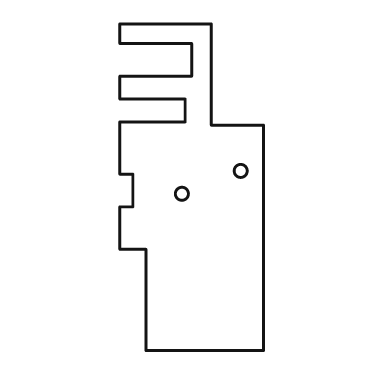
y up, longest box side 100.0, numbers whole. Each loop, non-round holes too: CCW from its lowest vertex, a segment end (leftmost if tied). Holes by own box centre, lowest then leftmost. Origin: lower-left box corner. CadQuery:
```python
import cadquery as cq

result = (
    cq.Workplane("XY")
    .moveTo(8.0, 0.0)
    .lineTo(44.0, 0.0)
    .lineTo(44.0, 69.0)
    .lineTo(28.0, 69.0)
    .lineTo(28.0, 100.0)
    .lineTo(0.0, 100.0)
    .lineTo(0.0, 94.0)
    .lineTo(22.0, 94.0)
    .lineTo(22.0, 84.0)
    .lineTo(0.0, 84.0)
    .lineTo(0.0, 77.0)
    .lineTo(20.0, 77.0)
    .lineTo(20.0, 70.0)
    .lineTo(0.0, 70.0)
    .lineTo(0.0, 54.0)
    .lineTo(4.0, 54.0)
    .lineTo(4.0, 44.0)
    .lineTo(0.0, 44.0)
    .lineTo(0.0, 31.0)
    .lineTo(8.0, 31.0)
    .close()
    .moveTo(19.0, 48.0)
    .circle(2.0)
    .moveTo(37.0, 55.0)
    .circle(2.0)
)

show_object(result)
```